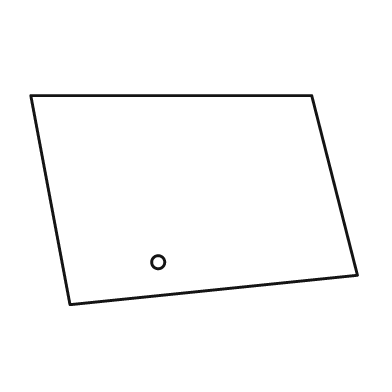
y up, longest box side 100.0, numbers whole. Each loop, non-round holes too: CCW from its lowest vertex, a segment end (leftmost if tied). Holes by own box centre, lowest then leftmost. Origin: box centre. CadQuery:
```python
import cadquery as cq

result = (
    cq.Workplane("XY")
    .moveTo(-38.0, -32.0)
    .lineTo(50.0, -23.0)
    .lineTo(36.0, 32.0)
    .lineTo(-50.0, 32.0)
    .close()
    .moveTo(-11.0, -19.0)
    .circle(2.0)
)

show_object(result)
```